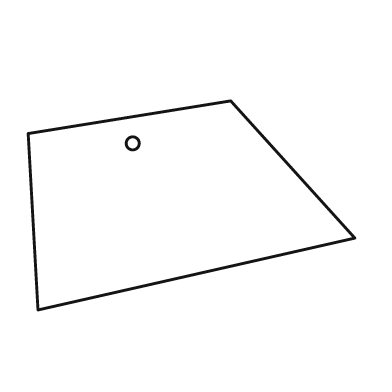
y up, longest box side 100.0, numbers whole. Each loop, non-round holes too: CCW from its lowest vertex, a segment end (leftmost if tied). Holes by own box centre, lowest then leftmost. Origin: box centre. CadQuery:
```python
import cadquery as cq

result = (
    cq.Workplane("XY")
    .moveTo(-47.0, -32.0)
    .lineTo(50.0, -10.0)
    .lineTo(12.0, 32.0)
    .lineTo(-50.0, 22.0)
    .close()
    .moveTo(-18.0, 19.0)
    .circle(2.0)
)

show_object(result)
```